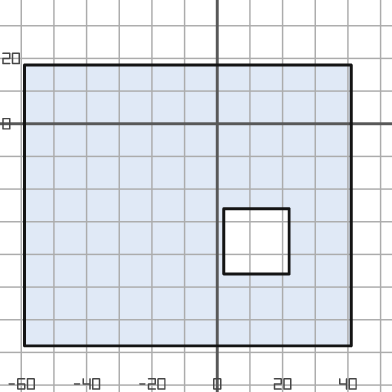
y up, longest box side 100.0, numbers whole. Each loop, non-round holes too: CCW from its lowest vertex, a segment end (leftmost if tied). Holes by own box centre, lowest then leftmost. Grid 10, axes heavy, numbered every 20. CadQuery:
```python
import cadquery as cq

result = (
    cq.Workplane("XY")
    .moveTo(-59.0, -68.0)
    .lineTo(41.0, -68.0)
    .lineTo(41.0, 18.0)
    .lineTo(-59.0, 18.0)
    .close()
    .moveTo(2.0, -46.0)
    .lineTo(22.0, -46.0)
    .lineTo(22.0, -26.0)
    .lineTo(2.0, -26.0)
    .close()
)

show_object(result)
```